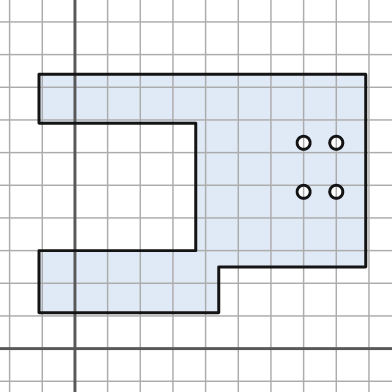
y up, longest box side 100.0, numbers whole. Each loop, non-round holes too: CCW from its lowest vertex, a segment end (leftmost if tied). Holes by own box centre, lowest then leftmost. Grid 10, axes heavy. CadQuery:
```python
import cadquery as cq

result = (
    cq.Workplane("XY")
    .moveTo(-11.0, 11.0)
    .lineTo(44.0, 11.0)
    .lineTo(44.0, 25.0)
    .lineTo(89.0, 25.0)
    .lineTo(89.0, 84.0)
    .lineTo(-11.0, 84.0)
    .lineTo(-11.0, 69.0)
    .lineTo(37.0, 69.0)
    .lineTo(37.0, 30.0)
    .lineTo(-11.0, 30.0)
    .close()
    .moveTo(70.0, 48.0)
    .circle(2.0)
    .moveTo(80.0, 48.0)
    .circle(2.0)
    .moveTo(70.0, 63.0)
    .circle(2.0)
    .moveTo(80.0, 63.0)
    .circle(2.0)
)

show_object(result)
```